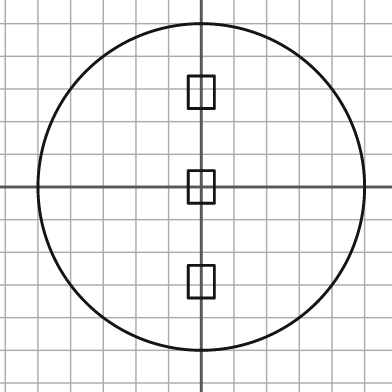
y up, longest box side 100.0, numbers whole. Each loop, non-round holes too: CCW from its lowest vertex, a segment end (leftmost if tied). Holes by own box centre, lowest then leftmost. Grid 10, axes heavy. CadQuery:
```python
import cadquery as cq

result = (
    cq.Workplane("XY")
    .moveTo(0.0, 0.0)
    .circle(50.0)
    .moveTo(-4.0, -34.0)
    .lineTo(4.0, -34.0)
    .lineTo(4.0, -24.0)
    .lineTo(-4.0, -24.0)
    .close()
    .moveTo(-4.0, -5.0)
    .lineTo(4.0, -5.0)
    .lineTo(4.0, 5.0)
    .lineTo(-4.0, 5.0)
    .close()
    .moveTo(-4.0, 24.0)
    .lineTo(4.0, 24.0)
    .lineTo(4.0, 34.0)
    .lineTo(-4.0, 34.0)
    .close()
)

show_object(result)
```